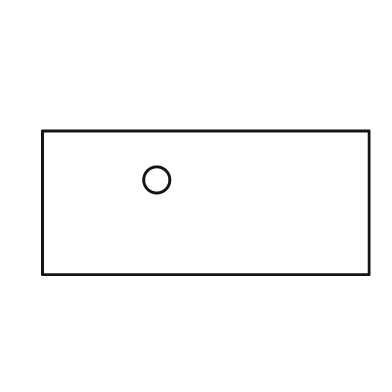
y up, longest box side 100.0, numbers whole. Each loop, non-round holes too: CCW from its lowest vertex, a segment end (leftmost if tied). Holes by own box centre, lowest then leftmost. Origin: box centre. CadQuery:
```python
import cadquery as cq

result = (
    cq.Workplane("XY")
    .moveTo(-50.0, -22.0)
    .lineTo(50.0, -22.0)
    .lineTo(50.0, 22.0)
    .lineTo(-50.0, 22.0)
    .close()
    .moveTo(-15.0, 7.0)
    .circle(4.0)
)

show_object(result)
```